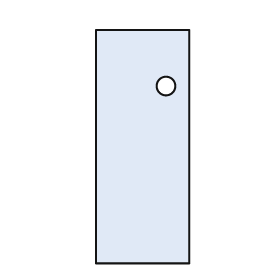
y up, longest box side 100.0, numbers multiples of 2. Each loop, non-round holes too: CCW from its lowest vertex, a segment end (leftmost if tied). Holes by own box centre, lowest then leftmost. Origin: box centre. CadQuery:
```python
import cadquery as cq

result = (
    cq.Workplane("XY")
    .moveTo(-20.0, -50.0)
    .lineTo(20.0, -50.0)
    .lineTo(20.0, 50.0)
    .lineTo(-20.0, 50.0)
    .close()
    .moveTo(10.0, 26.0)
    .circle(4.0)
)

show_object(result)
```